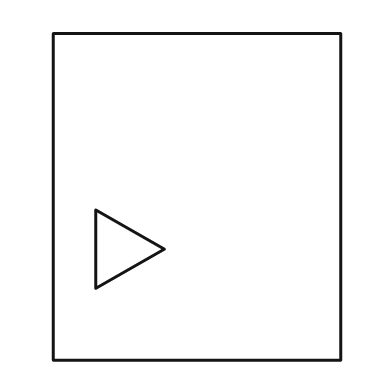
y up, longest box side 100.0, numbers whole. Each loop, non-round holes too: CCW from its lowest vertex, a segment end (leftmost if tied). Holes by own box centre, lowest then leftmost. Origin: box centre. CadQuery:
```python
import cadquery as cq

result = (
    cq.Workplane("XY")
    .moveTo(-44.0, -50.0)
    .lineTo(44.0, -50.0)
    .lineTo(44.0, 50.0)
    .lineTo(-44.0, 50.0)
    .close()
    .moveTo(-31.0, -28.0)
    .lineTo(-10.0, -16.0)
    .lineTo(-31.0, -4.0)
    .close()
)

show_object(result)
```